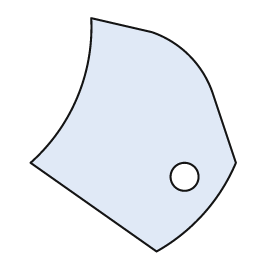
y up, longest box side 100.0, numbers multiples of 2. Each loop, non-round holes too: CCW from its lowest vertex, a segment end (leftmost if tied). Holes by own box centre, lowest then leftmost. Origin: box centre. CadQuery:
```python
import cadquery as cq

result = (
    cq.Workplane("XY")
    .moveTo(10.0, -50.0)
    .threePointArc((30.0, -34.0), (44.0, -12.0))
    .lineTo(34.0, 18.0)
    .threePointArc((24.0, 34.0), (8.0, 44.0))
    .lineTo(-18.0, 50.0)
    .threePointArc((-24.0, 16.0), (-44.0, -12.0))
    .close()
    .moveTo(22.0, -18.0)
    .circle(6.0)
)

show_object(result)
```